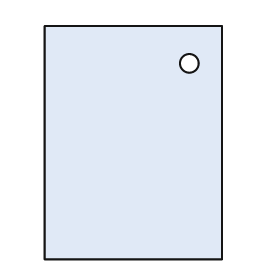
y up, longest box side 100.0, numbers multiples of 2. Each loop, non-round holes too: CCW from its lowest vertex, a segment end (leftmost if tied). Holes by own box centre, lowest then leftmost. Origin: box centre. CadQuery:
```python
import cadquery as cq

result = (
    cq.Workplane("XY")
    .moveTo(-38.0, -50.0)
    .lineTo(38.0, -50.0)
    .lineTo(38.0, 50.0)
    .lineTo(-38.0, 50.0)
    .close()
    .moveTo(24.0, 34.0)
    .circle(4.0)
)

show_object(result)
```